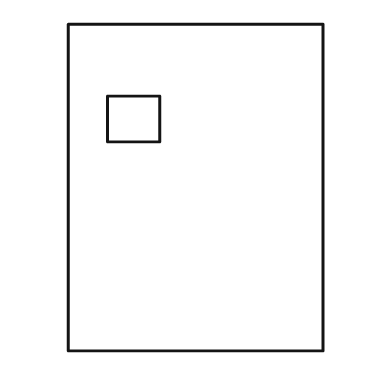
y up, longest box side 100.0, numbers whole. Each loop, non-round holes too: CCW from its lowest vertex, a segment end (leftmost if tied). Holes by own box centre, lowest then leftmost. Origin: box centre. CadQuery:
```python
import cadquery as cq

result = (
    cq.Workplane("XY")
    .moveTo(-39.0, -50.0)
    .lineTo(39.0, -50.0)
    .lineTo(39.0, 50.0)
    .lineTo(-39.0, 50.0)
    .close()
    .moveTo(-27.0, 14.0)
    .lineTo(-11.0, 14.0)
    .lineTo(-11.0, 28.0)
    .lineTo(-27.0, 28.0)
    .close()
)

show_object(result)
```